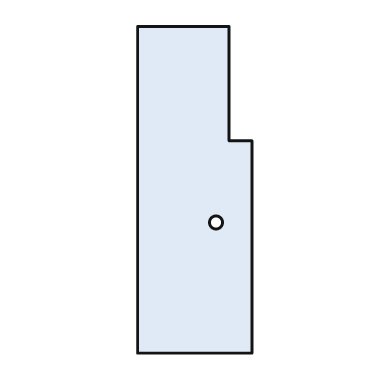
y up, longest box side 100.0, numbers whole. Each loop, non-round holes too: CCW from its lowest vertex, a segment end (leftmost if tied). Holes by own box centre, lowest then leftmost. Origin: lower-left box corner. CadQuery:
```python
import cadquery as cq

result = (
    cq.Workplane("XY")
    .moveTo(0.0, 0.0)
    .lineTo(35.0, 0.0)
    .lineTo(35.0, 65.0)
    .lineTo(28.0, 65.0)
    .lineTo(28.0, 100.0)
    .lineTo(0.0, 100.0)
    .close()
    .moveTo(24.0, 40.0)
    .circle(2.0)
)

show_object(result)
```